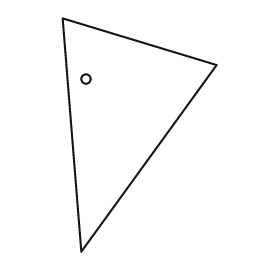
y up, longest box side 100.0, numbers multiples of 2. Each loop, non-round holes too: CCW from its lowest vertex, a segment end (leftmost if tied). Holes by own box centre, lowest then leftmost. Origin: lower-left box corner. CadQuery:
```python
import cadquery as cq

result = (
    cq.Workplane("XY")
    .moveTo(8.0, 0.0)
    .lineTo(66.0, 80.0)
    .lineTo(0.0, 100.0)
    .close()
    .moveTo(10.0, 74.0)
    .circle(2.0)
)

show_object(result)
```